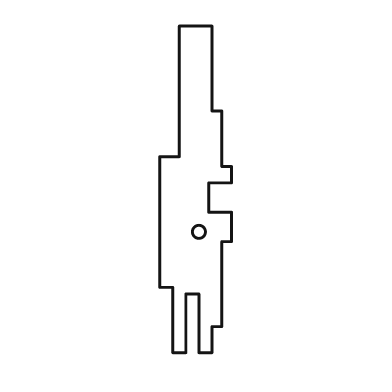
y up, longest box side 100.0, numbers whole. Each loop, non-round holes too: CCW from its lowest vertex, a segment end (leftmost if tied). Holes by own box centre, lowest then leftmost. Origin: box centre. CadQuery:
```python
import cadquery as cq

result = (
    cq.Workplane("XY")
    .moveTo(-7.0, -50.0)
    .lineTo(-3.0, -50.0)
    .lineTo(-3.0, -32.0)
    .lineTo(1.0, -32.0)
    .lineTo(1.0, -50.0)
    .lineTo(5.0, -50.0)
    .lineTo(5.0, -42.0)
    .lineTo(8.0, -42.0)
    .lineTo(8.0, -16.0)
    .lineTo(11.0, -16.0)
    .lineTo(11.0, -7.0)
    .lineTo(4.0, -7.0)
    .lineTo(4.0, 2.0)
    .lineTo(11.0, 2.0)
    .lineTo(11.0, 7.0)
    .lineTo(8.0, 7.0)
    .lineTo(8.0, 24.0)
    .lineTo(5.0, 24.0)
    .lineTo(5.0, 50.0)
    .lineTo(-5.0, 50.0)
    .lineTo(-5.0, 10.0)
    .lineTo(-11.0, 10.0)
    .lineTo(-11.0, -30.0)
    .lineTo(-7.0, -30.0)
    .close()
    .moveTo(1.0, -13.0)
    .circle(2.0)
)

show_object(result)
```